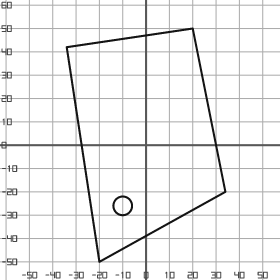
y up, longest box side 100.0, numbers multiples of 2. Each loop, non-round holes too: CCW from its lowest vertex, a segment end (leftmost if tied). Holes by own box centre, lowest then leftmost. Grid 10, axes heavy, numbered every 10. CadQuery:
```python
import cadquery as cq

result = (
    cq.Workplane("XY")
    .moveTo(-20.0, -50.0)
    .lineTo(34.0, -20.0)
    .lineTo(20.0, 50.0)
    .lineTo(-34.0, 42.0)
    .close()
    .moveTo(-10.0, -26.0)
    .circle(4.0)
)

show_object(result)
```